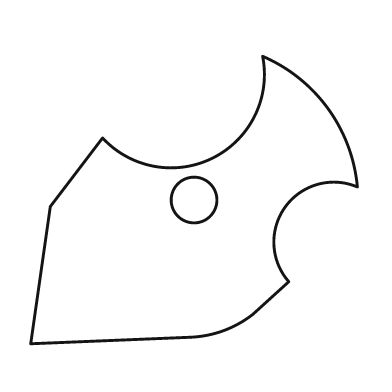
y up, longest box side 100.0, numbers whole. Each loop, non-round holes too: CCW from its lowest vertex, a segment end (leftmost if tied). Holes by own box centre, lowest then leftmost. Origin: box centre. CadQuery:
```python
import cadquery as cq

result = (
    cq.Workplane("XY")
    .moveTo(-50.0, -44.0)
    .lineTo(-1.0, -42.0)
    .threePointArc((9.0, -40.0), (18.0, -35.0))
    .lineTo(29.0, -25.0)
    .threePointArc((28.0, -2.0), (50.0, 4.0))
    .threePointArc((41.0, 28.0), (21.0, 44.0))
    .threePointArc((6.0, 13.0), (-28.0, 19.0))
    .lineTo(-44.0, -2.0)
    .close()
    .moveTo(0.0, 0.0)
    .circle(7.0)
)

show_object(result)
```